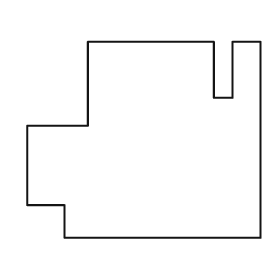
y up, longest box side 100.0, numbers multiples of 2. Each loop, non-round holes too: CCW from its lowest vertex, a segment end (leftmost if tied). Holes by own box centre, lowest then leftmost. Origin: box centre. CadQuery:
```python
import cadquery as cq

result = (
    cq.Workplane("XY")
    .moveTo(-34.0, -42.0)
    .lineTo(50.0, -42.0)
    .lineTo(50.0, 42.0)
    .lineTo(38.0, 42.0)
    .lineTo(38.0, 18.0)
    .lineTo(30.0, 18.0)
    .lineTo(30.0, 42.0)
    .lineTo(-24.0, 42.0)
    .lineTo(-24.0, 6.0)
    .lineTo(-50.0, 6.0)
    .lineTo(-50.0, -28.0)
    .lineTo(-34.0, -28.0)
    .close()
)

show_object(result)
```